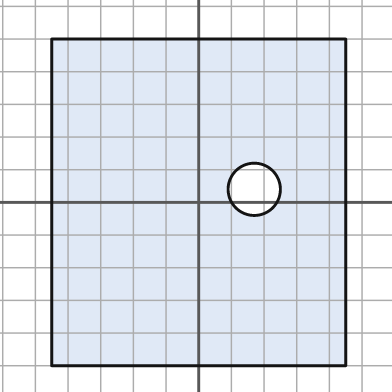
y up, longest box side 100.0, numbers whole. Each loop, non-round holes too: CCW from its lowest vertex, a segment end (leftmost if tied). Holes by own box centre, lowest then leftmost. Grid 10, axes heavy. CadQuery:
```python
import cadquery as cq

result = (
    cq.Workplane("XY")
    .moveTo(-45.0, -50.0)
    .lineTo(45.0, -50.0)
    .lineTo(45.0, 50.0)
    .lineTo(-45.0, 50.0)
    .close()
    .moveTo(17.0, 4.0)
    .circle(8.0)
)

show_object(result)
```